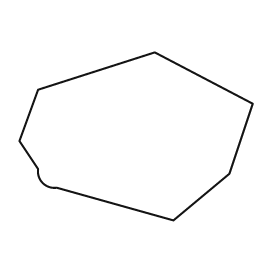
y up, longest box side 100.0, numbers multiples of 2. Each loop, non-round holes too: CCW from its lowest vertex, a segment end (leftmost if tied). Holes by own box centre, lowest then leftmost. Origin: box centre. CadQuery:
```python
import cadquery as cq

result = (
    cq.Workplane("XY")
    .moveTo(16.0, -36.0)
    .lineTo(40.0, -16.0)
    .lineTo(50.0, 14.0)
    .lineTo(8.0, 36.0)
    .lineTo(-42.0, 20.0)
    .lineTo(-50.0, -2.0)
    .lineTo(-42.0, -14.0)
    .threePointArc((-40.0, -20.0), (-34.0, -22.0))
    .close()
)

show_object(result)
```